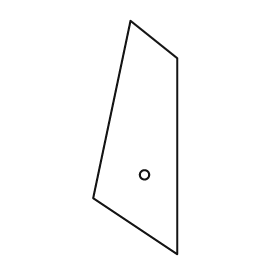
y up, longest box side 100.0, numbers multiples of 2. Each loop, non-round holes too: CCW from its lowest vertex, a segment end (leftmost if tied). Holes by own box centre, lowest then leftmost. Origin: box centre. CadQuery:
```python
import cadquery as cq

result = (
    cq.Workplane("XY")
    .moveTo(18.0, -50.0)
    .lineTo(18.0, 34.0)
    .lineTo(-2.0, 50.0)
    .lineTo(-18.0, -26.0)
    .close()
    .moveTo(4.0, -16.0)
    .circle(2.0)
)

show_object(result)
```